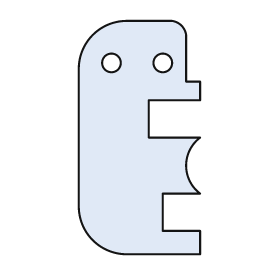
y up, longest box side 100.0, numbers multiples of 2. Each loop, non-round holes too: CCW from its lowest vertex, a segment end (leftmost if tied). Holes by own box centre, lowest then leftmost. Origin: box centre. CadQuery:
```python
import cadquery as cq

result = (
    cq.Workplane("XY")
    .moveTo(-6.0, -50.0)
    .lineTo(26.0, -50.0)
    .lineTo(26.0, -40.0)
    .lineTo(10.0, -40.0)
    .lineTo(10.0, -24.0)
    .lineTo(26.0, -24.0)
    .threePointArc((20.0, -12.0), (26.0, 0.0))
    .lineTo(4.0, 0.0)
    .lineTo(4.0, 16.0)
    .lineTo(26.0, 16.0)
    .lineTo(26.0, 24.0)
    .lineTo(20.0, 24.0)
    .lineTo(20.0, 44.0)
    .threePointArc((18.0, 48.0), (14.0, 50.0))
    .lineTo(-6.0, 50.0)
    .threePointArc((-20.0, 44.0), (-26.0, 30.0))
    .lineTo(-26.0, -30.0)
    .threePointArc((-20.0, -44.0), (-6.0, -50.0))
    .close()
    .moveTo(-12.0, 32.0)
    .circle(4.0)
    .moveTo(10.0, 32.0)
    .circle(4.0)
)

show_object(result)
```